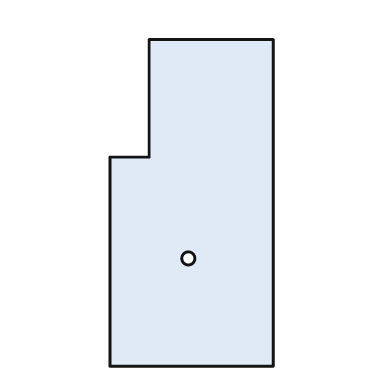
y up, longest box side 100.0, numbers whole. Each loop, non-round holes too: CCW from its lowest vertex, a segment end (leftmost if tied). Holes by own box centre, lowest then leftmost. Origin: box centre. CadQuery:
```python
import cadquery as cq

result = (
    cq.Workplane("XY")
    .moveTo(-25.0, -50.0)
    .lineTo(25.0, -50.0)
    .lineTo(25.0, 50.0)
    .lineTo(-13.0, 50.0)
    .lineTo(-13.0, 14.0)
    .lineTo(-25.0, 14.0)
    .close()
    .moveTo(-1.0, -17.0)
    .circle(2.0)
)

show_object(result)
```